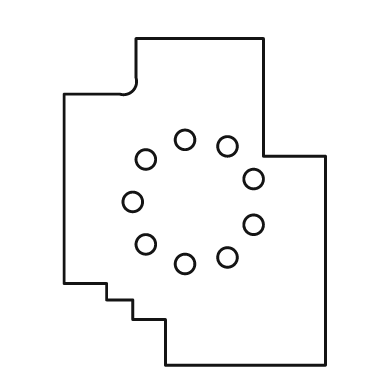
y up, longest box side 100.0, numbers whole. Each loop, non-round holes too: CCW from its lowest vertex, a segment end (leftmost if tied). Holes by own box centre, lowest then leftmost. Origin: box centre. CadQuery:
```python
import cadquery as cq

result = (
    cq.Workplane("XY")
    .moveTo(-9.0, -50.0)
    .lineTo(40.0, -50.0)
    .lineTo(40.0, 14.0)
    .lineTo(21.0, 14.0)
    .lineTo(21.0, 50.0)
    .lineTo(-18.0, 50.0)
    .lineTo(-18.0, 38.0)
    .threePointArc((-19.0, 34.0), (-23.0, 33.0))
    .lineTo(-40.0, 33.0)
    .lineTo(-40.0, -25.0)
    .lineTo(-27.0, -25.0)
    .lineTo(-27.0, -30.0)
    .lineTo(-19.0, -30.0)
    .lineTo(-19.0, -36.0)
    .lineTo(-9.0, -36.0)
    .close()
    .moveTo(-3.0, -19.0)
    .circle(3.0)
    .moveTo(10.0, -17.0)
    .circle(3.0)
    .moveTo(-15.0, -13.0)
    .circle(3.0)
    .moveTo(18.0, -7.0)
    .circle(3.0)
    .moveTo(-19.0, 0.0)
    .circle(3.0)
    .moveTo(18.0, 7.0)
    .circle(3.0)
    .moveTo(-15.0, 13.0)
    .circle(3.0)
    .moveTo(10.0, 17.0)
    .circle(3.0)
    .moveTo(-3.0, 19.0)
    .circle(3.0)
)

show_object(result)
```